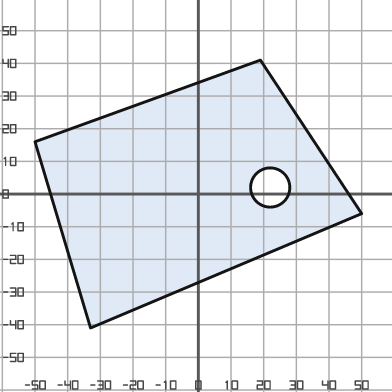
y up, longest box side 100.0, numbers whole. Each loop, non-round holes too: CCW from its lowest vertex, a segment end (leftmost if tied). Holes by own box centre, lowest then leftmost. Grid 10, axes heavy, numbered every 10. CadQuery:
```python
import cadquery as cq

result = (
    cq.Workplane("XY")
    .moveTo(-33.0, -41.0)
    .lineTo(50.0, -6.0)
    .lineTo(19.0, 41.0)
    .lineTo(-50.0, 16.0)
    .close()
    .moveTo(22.0, 2.0)
    .circle(6.0)
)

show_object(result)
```